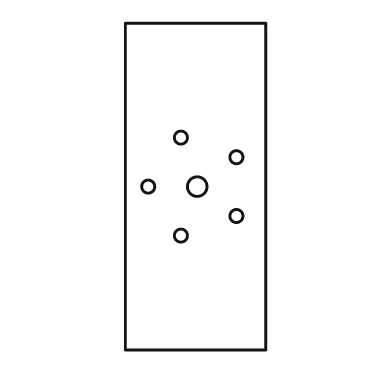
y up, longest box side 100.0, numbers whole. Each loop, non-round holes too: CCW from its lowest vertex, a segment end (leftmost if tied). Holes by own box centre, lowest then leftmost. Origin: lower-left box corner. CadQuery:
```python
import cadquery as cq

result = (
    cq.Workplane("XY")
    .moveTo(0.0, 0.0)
    .lineTo(43.0, 0.0)
    .lineTo(43.0, 100.0)
    .lineTo(0.0, 100.0)
    .close()
    .moveTo(17.0, 35.0)
    .circle(2.0)
    .moveTo(34.0, 41.0)
    .circle(2.0)
    .moveTo(7.0, 50.0)
    .circle(2.0)
    .moveTo(22.0, 50.0)
    .circle(3.0)
    .moveTo(34.0, 59.0)
    .circle(2.0)
    .moveTo(17.0, 65.0)
    .circle(2.0)
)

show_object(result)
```